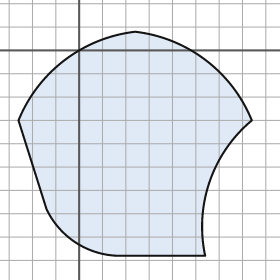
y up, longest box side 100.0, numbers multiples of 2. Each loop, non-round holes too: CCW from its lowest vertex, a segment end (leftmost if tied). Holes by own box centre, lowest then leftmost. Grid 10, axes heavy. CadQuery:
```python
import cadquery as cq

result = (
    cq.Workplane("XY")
    .moveTo(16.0, -88.0)
    .lineTo(54.0, -88.0)
    .threePointArc((56.0, -56.0), (74.0, -30.0))
    .threePointArc((54.0, -4.0), (24.0, 8.0))
    .threePointArc((-6.0, -4.0), (-26.0, -30.0))
    .lineTo(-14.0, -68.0)
    .threePointArc((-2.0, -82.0), (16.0, -88.0))
    .close()
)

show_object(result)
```